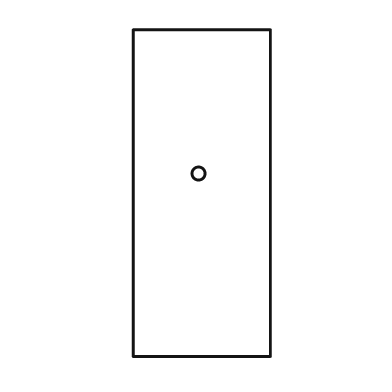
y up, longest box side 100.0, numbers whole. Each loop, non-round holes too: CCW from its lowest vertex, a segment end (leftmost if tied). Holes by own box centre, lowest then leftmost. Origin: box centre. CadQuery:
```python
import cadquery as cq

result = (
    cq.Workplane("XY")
    .moveTo(-21.0, -50.0)
    .lineTo(21.0, -50.0)
    .lineTo(21.0, 50.0)
    .lineTo(-21.0, 50.0)
    .close()
    .moveTo(-1.0, 6.0)
    .circle(2.0)
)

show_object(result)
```